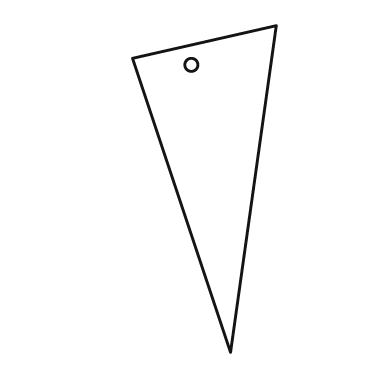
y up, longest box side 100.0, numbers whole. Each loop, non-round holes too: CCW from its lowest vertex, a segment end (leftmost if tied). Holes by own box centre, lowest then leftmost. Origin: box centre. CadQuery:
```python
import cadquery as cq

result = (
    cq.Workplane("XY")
    .moveTo(8.0, -50.0)
    .lineTo(22.0, 50.0)
    .lineTo(-22.0, 40.0)
    .close()
    .moveTo(-4.0, 38.0)
    .circle(2.0)
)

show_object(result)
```